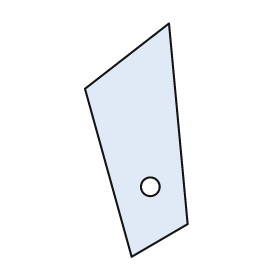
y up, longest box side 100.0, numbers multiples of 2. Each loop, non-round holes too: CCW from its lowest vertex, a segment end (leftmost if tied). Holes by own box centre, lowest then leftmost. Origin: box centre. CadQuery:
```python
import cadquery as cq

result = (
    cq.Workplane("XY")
    .moveTo(-2.0, -50.0)
    .lineTo(22.0, -36.0)
    .lineTo(14.0, 50.0)
    .lineTo(-22.0, 22.0)
    .close()
    .moveTo(6.0, -20.0)
    .circle(4.0)
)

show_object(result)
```